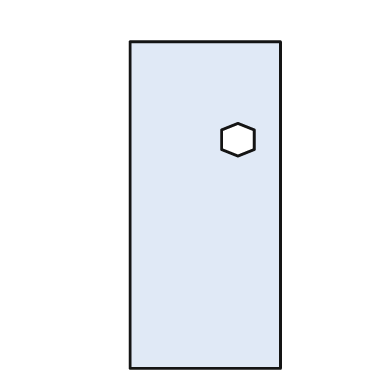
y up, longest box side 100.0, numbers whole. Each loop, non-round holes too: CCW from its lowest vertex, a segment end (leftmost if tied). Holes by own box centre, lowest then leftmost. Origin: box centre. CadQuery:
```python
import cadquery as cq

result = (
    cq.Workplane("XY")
    .moveTo(-23.0, -50.0)
    .lineTo(23.0, -50.0)
    .lineTo(23.0, 50.0)
    .lineTo(-23.0, 50.0)
    .close()
    .moveTo(10.0, 15.0)
    .lineTo(15.0, 17.0)
    .lineTo(15.0, 23.0)
    .lineTo(10.0, 25.0)
    .lineTo(5.0, 23.0)
    .lineTo(5.0, 17.0)
    .close()
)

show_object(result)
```